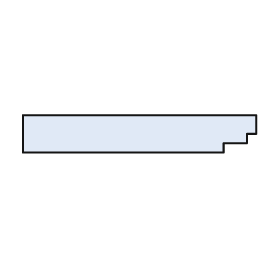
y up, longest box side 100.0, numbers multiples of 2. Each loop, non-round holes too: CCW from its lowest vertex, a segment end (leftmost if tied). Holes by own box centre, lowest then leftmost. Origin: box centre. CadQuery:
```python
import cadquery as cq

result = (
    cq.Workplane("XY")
    .moveTo(-50.0, -8.0)
    .lineTo(36.0, -8.0)
    .lineTo(36.0, -4.0)
    .lineTo(46.0, -4.0)
    .lineTo(46.0, 0.0)
    .lineTo(50.0, 0.0)
    .lineTo(50.0, 8.0)
    .lineTo(-50.0, 8.0)
    .close()
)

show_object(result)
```